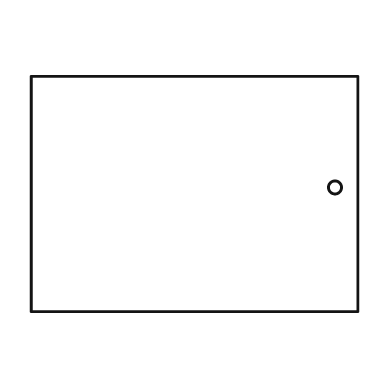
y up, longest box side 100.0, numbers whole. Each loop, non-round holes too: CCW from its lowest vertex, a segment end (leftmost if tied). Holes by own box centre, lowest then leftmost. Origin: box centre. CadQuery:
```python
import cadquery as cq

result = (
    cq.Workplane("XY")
    .moveTo(-50.0, -36.0)
    .lineTo(50.0, -36.0)
    .lineTo(50.0, 36.0)
    .lineTo(-50.0, 36.0)
    .close()
    .moveTo(43.0, 2.0)
    .circle(2.0)
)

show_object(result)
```